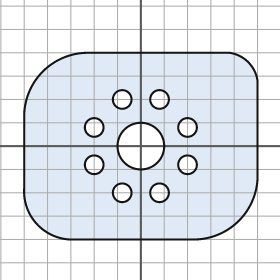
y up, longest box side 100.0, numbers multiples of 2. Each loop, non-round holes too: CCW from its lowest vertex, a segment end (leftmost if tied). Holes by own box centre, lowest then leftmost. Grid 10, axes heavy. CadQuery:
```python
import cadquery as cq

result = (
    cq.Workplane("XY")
    .moveTo(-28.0, -40.0)
    .lineTo(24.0, -40.0)
    .threePointArc((42.0, -32.0), (50.0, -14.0))
    .lineTo(50.0, 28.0)
    .threePointArc((46.0, 36.0), (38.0, 40.0))
    .lineTo(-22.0, 40.0)
    .threePointArc((-42.0, 32.0), (-50.0, 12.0))
    .lineTo(-50.0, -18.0)
    .threePointArc((-44.0, -34.0), (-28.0, -40.0))
    .close()
    .moveTo(-8.0, -20.0)
    .circle(4.0)
    .moveTo(8.0, -20.0)
    .circle(4.0)
    .moveTo(-20.0, -8.0)
    .circle(4.0)
    .moveTo(20.0, -8.0)
    .circle(4.0)
    .moveTo(0.0, 0.0)
    .circle(10.0)
    .moveTo(-20.0, 8.0)
    .circle(4.0)
    .moveTo(20.0, 8.0)
    .circle(4.0)
    .moveTo(-8.0, 20.0)
    .circle(4.0)
    .moveTo(8.0, 20.0)
    .circle(4.0)
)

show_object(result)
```